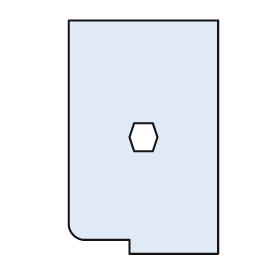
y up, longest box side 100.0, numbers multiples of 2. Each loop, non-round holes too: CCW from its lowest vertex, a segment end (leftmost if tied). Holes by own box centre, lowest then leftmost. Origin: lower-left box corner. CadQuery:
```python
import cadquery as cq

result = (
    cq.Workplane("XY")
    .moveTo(26.0, 0.0)
    .lineTo(64.0, 0.0)
    .lineTo(64.0, 100.0)
    .lineTo(0.0, 100.0)
    .lineTo(0.0, 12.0)
    .threePointArc((2.0, 8.0), (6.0, 6.0))
    .lineTo(26.0, 6.0)
    .close()
    .moveTo(28.0, 44.0)
    .lineTo(36.0, 44.0)
    .lineTo(38.0, 50.0)
    .lineTo(36.0, 56.0)
    .lineTo(28.0, 56.0)
    .lineTo(26.0, 50.0)
    .close()
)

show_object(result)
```